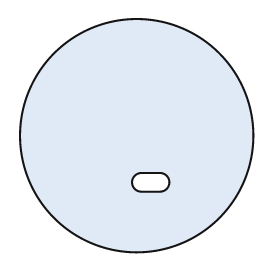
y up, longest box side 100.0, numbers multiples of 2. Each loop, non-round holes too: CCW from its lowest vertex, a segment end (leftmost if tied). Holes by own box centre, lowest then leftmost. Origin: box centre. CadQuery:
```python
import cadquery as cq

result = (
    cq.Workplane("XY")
    .moveTo(0.0, 0.0)
    .circle(50.0)
    .moveTo(2.0, -24.0)
    .lineTo(10.0, -24.0)
    .threePointArc((14.0, -20.0), (10.0, -16.0))
    .lineTo(2.0, -16.0)
    .threePointArc((-2.0, -20.0), (2.0, -24.0))
    .close()
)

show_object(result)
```